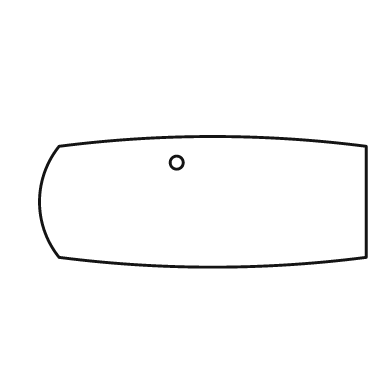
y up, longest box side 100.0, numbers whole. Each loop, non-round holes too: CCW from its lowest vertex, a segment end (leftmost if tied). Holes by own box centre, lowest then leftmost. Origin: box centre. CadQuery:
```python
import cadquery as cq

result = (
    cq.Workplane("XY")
    .moveTo(-44.0, -17.0)
    .threePointArc((3.0, -20.0), (50.0, -17.0))
    .lineTo(50.0, 17.0)
    .threePointArc((3.0, 20.0), (-44.0, 17.0))
    .threePointArc((-50.0, 0.0), (-44.0, -17.0))
    .close()
    .moveTo(-8.0, 12.0)
    .circle(2.0)
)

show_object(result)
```